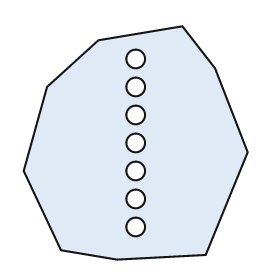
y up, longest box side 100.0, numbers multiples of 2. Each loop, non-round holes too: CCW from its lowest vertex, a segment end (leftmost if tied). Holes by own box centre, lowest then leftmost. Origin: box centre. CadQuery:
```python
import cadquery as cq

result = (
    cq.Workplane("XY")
    .moveTo(-8.0, -50.0)
    .lineTo(30.0, -48.0)
    .lineTo(48.0, -4.0)
    .lineTo(34.0, 32.0)
    .lineTo(20.0, 50.0)
    .lineTo(-16.0, 44.0)
    .lineTo(-38.0, 24.0)
    .lineTo(-48.0, -12.0)
    .lineTo(-32.0, -46.0)
    .close()
    .moveTo(0.0, -36.0)
    .circle(4.0)
    .moveTo(0.0, -24.0)
    .circle(4.0)
    .moveTo(0.0, -12.0)
    .circle(4.0)
    .moveTo(0.0, 0.0)
    .circle(4.0)
    .moveTo(0.0, 12.0)
    .circle(4.0)
    .moveTo(0.0, 24.0)
    .circle(4.0)
    .moveTo(0.0, 36.0)
    .circle(4.0)
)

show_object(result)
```